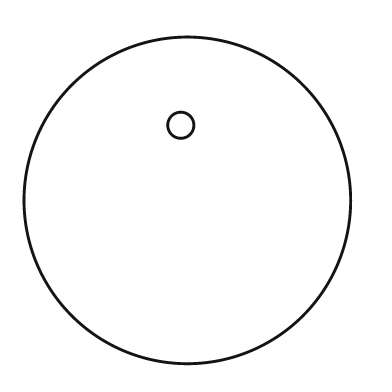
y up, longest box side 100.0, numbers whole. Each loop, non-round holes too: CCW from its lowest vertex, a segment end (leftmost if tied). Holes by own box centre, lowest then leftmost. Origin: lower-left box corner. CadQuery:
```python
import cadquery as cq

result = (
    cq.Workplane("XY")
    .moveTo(50.0, 50.0)
    .circle(50.0)
    .moveTo(48.0, 73.0)
    .circle(4.0)
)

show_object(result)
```